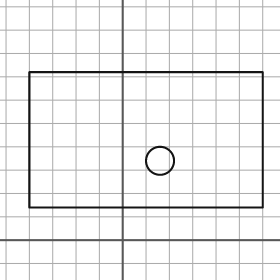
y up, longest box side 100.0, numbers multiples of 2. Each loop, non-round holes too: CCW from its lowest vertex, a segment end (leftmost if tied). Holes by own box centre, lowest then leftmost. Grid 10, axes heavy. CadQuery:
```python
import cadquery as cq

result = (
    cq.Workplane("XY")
    .moveTo(-40.0, 14.0)
    .lineTo(60.0, 14.0)
    .lineTo(60.0, 72.0)
    .lineTo(-40.0, 72.0)
    .close()
    .moveTo(16.0, 34.0)
    .circle(6.0)
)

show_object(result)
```